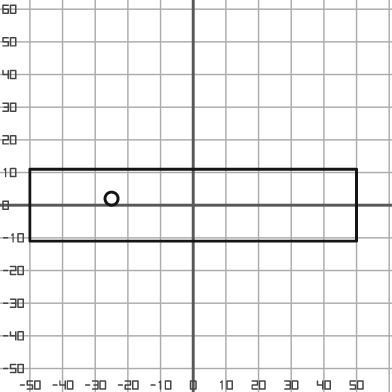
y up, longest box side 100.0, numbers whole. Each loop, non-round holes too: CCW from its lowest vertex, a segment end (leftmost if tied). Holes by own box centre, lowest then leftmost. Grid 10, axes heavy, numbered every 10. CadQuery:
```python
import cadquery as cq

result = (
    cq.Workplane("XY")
    .moveTo(-50.0, -11.0)
    .lineTo(50.0, -11.0)
    .lineTo(50.0, 11.0)
    .lineTo(-50.0, 11.0)
    .close()
    .moveTo(-25.0, 2.0)
    .circle(2.0)
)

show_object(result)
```